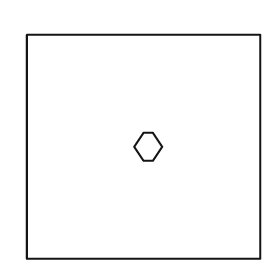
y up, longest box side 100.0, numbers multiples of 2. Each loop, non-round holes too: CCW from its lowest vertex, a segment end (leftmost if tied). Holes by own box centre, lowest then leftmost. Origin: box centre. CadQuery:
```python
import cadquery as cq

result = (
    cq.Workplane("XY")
    .moveTo(-50.0, -48.0)
    .lineTo(50.0, -48.0)
    .lineTo(50.0, 48.0)
    .lineTo(-50.0, 48.0)
    .close()
    .moveTo(0.0, -6.0)
    .lineTo(4.0, -6.0)
    .lineTo(8.0, 0.0)
    .lineTo(4.0, 6.0)
    .lineTo(0.0, 6.0)
    .lineTo(-4.0, 0.0)
    .close()
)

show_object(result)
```